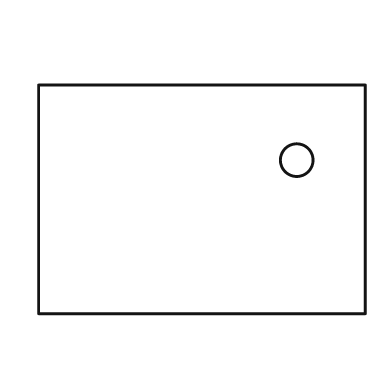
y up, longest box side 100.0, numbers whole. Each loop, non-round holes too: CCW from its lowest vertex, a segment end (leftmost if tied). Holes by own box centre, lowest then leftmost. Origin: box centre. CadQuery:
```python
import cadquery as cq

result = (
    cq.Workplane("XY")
    .moveTo(-50.0, -35.0)
    .lineTo(50.0, -35.0)
    .lineTo(50.0, 35.0)
    .lineTo(-50.0, 35.0)
    .close()
    .moveTo(29.0, 12.0)
    .circle(5.0)
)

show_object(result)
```